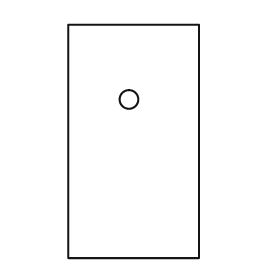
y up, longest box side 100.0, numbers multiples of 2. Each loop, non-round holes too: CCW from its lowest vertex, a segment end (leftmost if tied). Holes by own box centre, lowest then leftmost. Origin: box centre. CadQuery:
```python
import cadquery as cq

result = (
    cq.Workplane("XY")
    .moveTo(-28.0, -50.0)
    .lineTo(28.0, -50.0)
    .lineTo(28.0, 50.0)
    .lineTo(-28.0, 50.0)
    .close()
    .moveTo(-2.0, 18.0)
    .circle(4.0)
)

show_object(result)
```